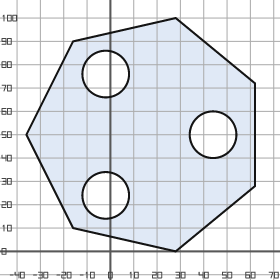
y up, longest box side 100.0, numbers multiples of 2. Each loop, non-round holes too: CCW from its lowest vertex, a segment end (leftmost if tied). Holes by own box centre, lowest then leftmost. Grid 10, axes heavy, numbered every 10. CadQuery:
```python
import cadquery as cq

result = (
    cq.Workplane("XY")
    .moveTo(28.0, 0.0)
    .lineTo(62.0, 28.0)
    .lineTo(62.0, 72.0)
    .lineTo(28.0, 100.0)
    .lineTo(-16.0, 90.0)
    .lineTo(-36.0, 50.0)
    .lineTo(-16.0, 10.0)
    .close()
    .moveTo(-2.0, 24.0)
    .circle(10.0)
    .moveTo(44.0, 50.0)
    .circle(10.0)
    .moveTo(-2.0, 76.0)
    .circle(10.0)
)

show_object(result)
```